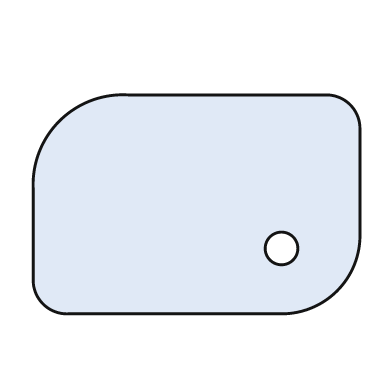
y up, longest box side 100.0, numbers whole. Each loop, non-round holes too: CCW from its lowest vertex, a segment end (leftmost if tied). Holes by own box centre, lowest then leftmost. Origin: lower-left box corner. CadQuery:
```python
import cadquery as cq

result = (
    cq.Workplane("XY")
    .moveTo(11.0, 0.0)
    .lineTo(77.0, 0.0)
    .threePointArc((93.0, 7.0), (100.0, 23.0))
    .lineTo(100.0, 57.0)
    .threePointArc((97.0, 64.0), (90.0, 67.0))
    .lineTo(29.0, 67.0)
    .threePointArc((8.0, 59.0), (0.0, 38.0))
    .lineTo(0.0, 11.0)
    .threePointArc((3.0, 3.0), (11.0, 0.0))
    .close()
    .moveTo(76.0, 20.0)
    .circle(5.0)
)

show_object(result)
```